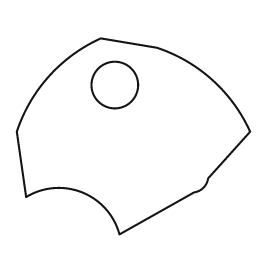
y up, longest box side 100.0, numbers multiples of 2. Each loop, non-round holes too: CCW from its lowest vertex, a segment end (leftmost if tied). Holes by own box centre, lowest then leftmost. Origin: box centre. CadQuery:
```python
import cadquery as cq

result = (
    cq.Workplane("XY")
    .moveTo(-6.0, -42.0)
    .lineTo(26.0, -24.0)
    .threePointArc((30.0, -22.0), (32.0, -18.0))
    .lineTo(50.0, 2.0)
    .threePointArc((34.0, 24.0), (10.0, 38.0))
    .lineTo(-14.0, 42.0)
    .threePointArc((-36.0, 26.0), (-50.0, 2.0))
    .lineTo(-46.0, -26.0)
    .threePointArc((-22.0, -24.0), (-6.0, -42.0))
    .close()
    .moveTo(-8.0, 22.0)
    .circle(10.0)
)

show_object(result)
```